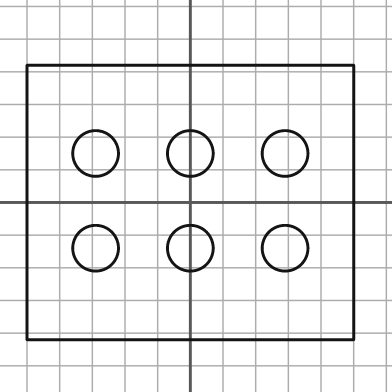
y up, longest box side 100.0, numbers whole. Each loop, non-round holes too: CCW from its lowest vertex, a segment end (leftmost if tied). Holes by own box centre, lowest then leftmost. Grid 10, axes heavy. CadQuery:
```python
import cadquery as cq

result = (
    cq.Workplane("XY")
    .moveTo(-50.0, -42.0)
    .lineTo(50.0, -42.0)
    .lineTo(50.0, 42.0)
    .lineTo(-50.0, 42.0)
    .close()
    .moveTo(-29.0, -14.0)
    .circle(7.0)
    .moveTo(0.0, -14.0)
    .circle(7.0)
    .moveTo(29.0, -14.0)
    .circle(7.0)
    .moveTo(-29.0, 15.0)
    .circle(7.0)
    .moveTo(0.0, 15.0)
    .circle(7.0)
    .moveTo(29.0, 15.0)
    .circle(7.0)
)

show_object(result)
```